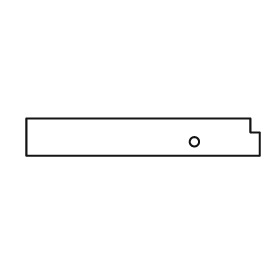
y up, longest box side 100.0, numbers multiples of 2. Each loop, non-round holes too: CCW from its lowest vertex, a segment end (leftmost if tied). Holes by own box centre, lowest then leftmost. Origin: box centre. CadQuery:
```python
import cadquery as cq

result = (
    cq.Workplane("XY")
    .moveTo(-50.0, -8.0)
    .lineTo(50.0, -8.0)
    .lineTo(50.0, 2.0)
    .lineTo(46.0, 2.0)
    .lineTo(46.0, 8.0)
    .lineTo(-50.0, 8.0)
    .close()
    .moveTo(22.0, -2.0)
    .circle(2.0)
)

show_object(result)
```